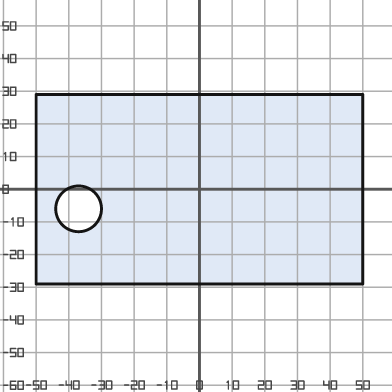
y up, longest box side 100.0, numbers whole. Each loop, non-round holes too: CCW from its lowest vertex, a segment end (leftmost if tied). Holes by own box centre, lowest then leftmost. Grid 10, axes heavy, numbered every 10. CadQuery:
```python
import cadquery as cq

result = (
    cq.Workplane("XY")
    .moveTo(-50.0, -29.0)
    .lineTo(50.0, -29.0)
    .lineTo(50.0, 29.0)
    .lineTo(-50.0, 29.0)
    .close()
    .moveTo(-37.0, -6.0)
    .circle(7.0)
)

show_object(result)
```